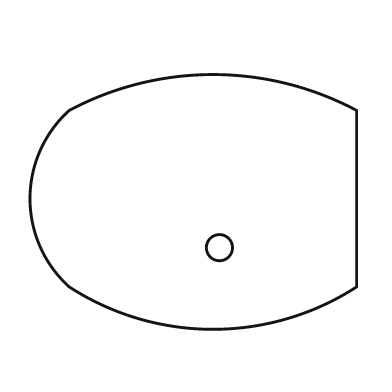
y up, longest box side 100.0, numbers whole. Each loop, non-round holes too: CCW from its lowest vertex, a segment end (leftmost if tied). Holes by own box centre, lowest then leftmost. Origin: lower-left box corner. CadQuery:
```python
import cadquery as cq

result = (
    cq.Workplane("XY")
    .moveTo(12.0, 13.0)
    .threePointArc((56.0, 0.0), (100.0, 13.0))
    .lineTo(100.0, 67.0)
    .threePointArc((56.0, 78.0), (12.0, 67.0))
    .threePointArc((0.0, 40.0), (12.0, 13.0))
    .close()
    .moveTo(58.0, 25.0)
    .circle(4.0)
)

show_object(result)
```